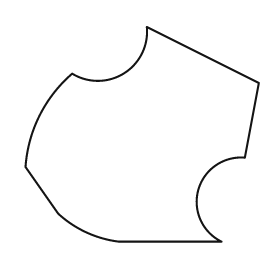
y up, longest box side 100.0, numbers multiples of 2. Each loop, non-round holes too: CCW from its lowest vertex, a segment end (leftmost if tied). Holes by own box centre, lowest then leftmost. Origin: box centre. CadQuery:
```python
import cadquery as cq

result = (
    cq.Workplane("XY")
    .moveTo(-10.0, -46.0)
    .lineTo(34.0, -46.0)
    .threePointArc((24.0, -24.0), (44.0, -10.0))
    .lineTo(50.0, 22.0)
    .lineTo(2.0, 46.0)
    .threePointArc((-8.0, 26.0), (-30.0, 26.0))
    .threePointArc((-44.0, 8.0), (-50.0, -14.0))
    .lineTo(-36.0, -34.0)
    .threePointArc((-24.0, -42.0), (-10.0, -46.0))
    .close()
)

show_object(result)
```